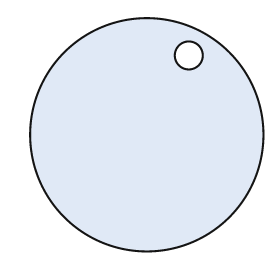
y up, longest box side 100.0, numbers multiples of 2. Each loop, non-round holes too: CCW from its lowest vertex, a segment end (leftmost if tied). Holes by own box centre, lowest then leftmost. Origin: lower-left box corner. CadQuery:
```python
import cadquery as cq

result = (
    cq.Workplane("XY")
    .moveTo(50.0, 50.0)
    .circle(50.0)
    .moveTo(68.0, 84.0)
    .circle(6.0)
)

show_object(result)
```